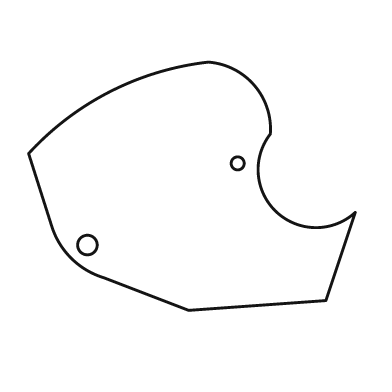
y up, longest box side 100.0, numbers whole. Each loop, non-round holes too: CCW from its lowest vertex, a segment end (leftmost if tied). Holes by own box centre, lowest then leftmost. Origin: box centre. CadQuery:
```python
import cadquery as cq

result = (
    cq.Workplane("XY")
    .moveTo(-1.0, -38.0)
    .lineTo(41.0, -35.0)
    .lineTo(50.0, -8.0)
    .threePointArc((26.0, -8.0), (24.0, 16.0))
    .threePointArc((19.0, 31.0), (5.0, 38.0))
    .threePointArc((-25.0, 29.0), (-50.0, 10.0))
    .lineTo(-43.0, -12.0)
    .threePointArc((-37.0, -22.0), (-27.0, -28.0))
    .close()
    .moveTo(-32.0, -18.0)
    .circle(3.0)
    .moveTo(14.0, 7.0)
    .circle(2.0)
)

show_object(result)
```